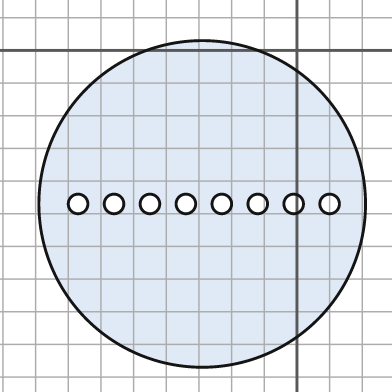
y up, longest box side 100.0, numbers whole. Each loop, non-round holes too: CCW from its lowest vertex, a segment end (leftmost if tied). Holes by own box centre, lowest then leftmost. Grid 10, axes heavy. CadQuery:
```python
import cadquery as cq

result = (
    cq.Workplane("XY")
    .moveTo(-29.0, -47.0)
    .circle(50.0)
    .moveTo(-67.0, -47.0)
    .circle(3.0)
    .moveTo(-56.0, -47.0)
    .circle(3.0)
    .moveTo(-45.0, -47.0)
    .circle(3.0)
    .moveTo(-34.0, -47.0)
    .circle(3.0)
    .moveTo(-23.0, -47.0)
    .circle(3.0)
    .moveTo(-12.0, -47.0)
    .circle(3.0)
    .moveTo(-1.0, -47.0)
    .circle(3.0)
    .moveTo(10.0, -47.0)
    .circle(3.0)
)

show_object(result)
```